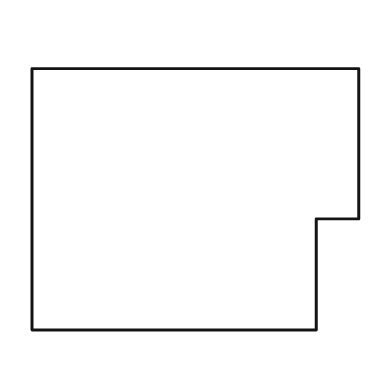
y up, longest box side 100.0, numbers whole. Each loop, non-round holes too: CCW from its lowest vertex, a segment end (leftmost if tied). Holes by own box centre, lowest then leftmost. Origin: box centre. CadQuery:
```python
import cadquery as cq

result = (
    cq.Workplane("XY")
    .moveTo(-50.0, -40.0)
    .lineTo(37.0, -40.0)
    .lineTo(37.0, -6.0)
    .lineTo(50.0, -6.0)
    .lineTo(50.0, 40.0)
    .lineTo(-50.0, 40.0)
    .close()
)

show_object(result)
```